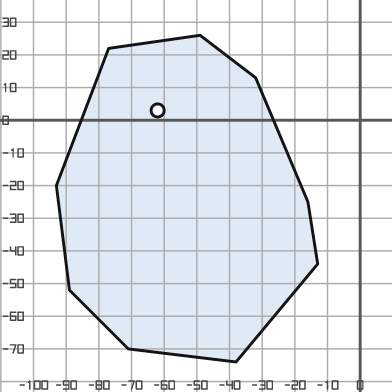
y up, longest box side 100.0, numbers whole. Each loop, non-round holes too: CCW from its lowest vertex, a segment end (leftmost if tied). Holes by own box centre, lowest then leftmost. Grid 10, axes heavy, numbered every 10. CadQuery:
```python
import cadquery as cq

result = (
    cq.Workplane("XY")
    .moveTo(-38.0, -74.0)
    .lineTo(-13.0, -44.0)
    .lineTo(-16.0, -25.0)
    .lineTo(-32.0, 13.0)
    .lineTo(-49.0, 26.0)
    .lineTo(-77.0, 22.0)
    .lineTo(-93.0, -20.0)
    .lineTo(-89.0, -52.0)
    .lineTo(-71.0, -70.0)
    .close()
    .moveTo(-62.0, 3.0)
    .circle(2.0)
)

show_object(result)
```